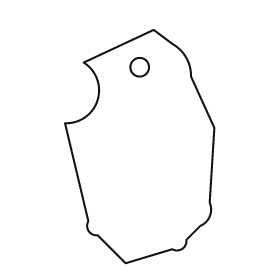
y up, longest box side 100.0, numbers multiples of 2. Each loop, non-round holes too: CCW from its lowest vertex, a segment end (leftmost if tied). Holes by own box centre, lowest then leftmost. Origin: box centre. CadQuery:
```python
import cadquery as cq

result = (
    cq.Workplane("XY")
    .moveTo(-6.0, -50.0)
    .lineTo(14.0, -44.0)
    .threePointArc((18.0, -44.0), (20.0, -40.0))
    .lineTo(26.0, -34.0)
    .threePointArc((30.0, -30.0), (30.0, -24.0))
    .lineTo(32.0, 8.0)
    .lineTo(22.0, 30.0)
    .threePointArc((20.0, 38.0), (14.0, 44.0))
    .lineTo(6.0, 50.0)
    .lineTo(-24.0, 36.0)
    .threePointArc((-18.0, 20.0), (-32.0, 10.0))
    .lineTo(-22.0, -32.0)
    .threePointArc((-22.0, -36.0), (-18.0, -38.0))
    .close()
    .moveTo(0.0, 34.0)
    .circle(4.0)
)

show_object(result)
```